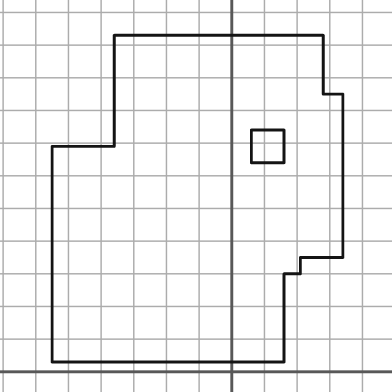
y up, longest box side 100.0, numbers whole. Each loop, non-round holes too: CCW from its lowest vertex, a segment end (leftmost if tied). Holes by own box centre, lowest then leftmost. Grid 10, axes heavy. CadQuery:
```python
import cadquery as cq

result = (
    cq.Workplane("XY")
    .moveTo(-55.0, 3.0)
    .lineTo(16.0, 3.0)
    .lineTo(16.0, 30.0)
    .lineTo(21.0, 30.0)
    .lineTo(21.0, 35.0)
    .lineTo(34.0, 35.0)
    .lineTo(34.0, 85.0)
    .lineTo(28.0, 85.0)
    .lineTo(28.0, 103.0)
    .lineTo(-36.0, 103.0)
    .lineTo(-36.0, 69.0)
    .lineTo(-55.0, 69.0)
    .close()
    .moveTo(6.0, 64.0)
    .lineTo(16.0, 64.0)
    .lineTo(16.0, 74.0)
    .lineTo(6.0, 74.0)
    .close()
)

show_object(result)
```